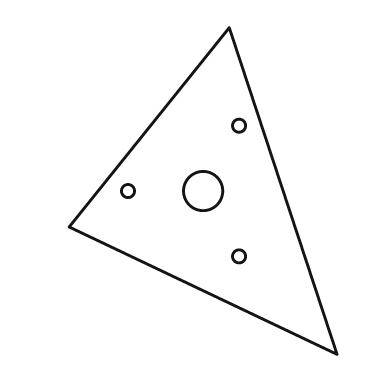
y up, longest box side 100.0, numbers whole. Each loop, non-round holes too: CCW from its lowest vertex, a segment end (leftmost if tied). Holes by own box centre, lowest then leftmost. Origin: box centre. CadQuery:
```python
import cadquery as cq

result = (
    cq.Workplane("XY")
    .moveTo(41.0, -50.0)
    .lineTo(8.0, 50.0)
    .lineTo(-41.0, -11.0)
    .close()
    .moveTo(11.0, -20.0)
    .circle(2.0)
    .moveTo(-23.0, 0.0)
    .circle(2.0)
    .moveTo(0.0, 0.0)
    .circle(6.0)
    .moveTo(11.0, 20.0)
    .circle(2.0)
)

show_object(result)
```